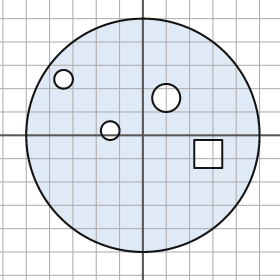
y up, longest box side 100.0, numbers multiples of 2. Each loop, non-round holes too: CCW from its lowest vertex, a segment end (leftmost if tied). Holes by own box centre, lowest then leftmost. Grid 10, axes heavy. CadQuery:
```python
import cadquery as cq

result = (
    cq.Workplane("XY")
    .moveTo(0.0, 0.0)
    .circle(50.0)
    .moveTo(22.0, -14.0)
    .lineTo(34.0, -14.0)
    .lineTo(34.0, -2.0)
    .lineTo(22.0, -2.0)
    .close()
    .moveTo(-14.0, 2.0)
    .circle(4.0)
    .moveTo(10.0, 16.0)
    .circle(6.0)
    .moveTo(-34.0, 24.0)
    .circle(4.0)
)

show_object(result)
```